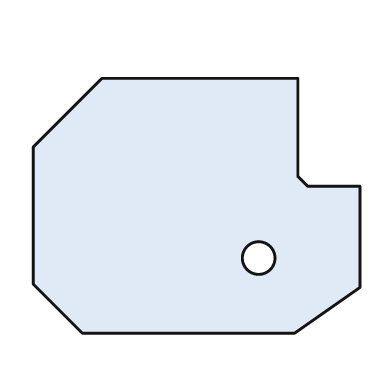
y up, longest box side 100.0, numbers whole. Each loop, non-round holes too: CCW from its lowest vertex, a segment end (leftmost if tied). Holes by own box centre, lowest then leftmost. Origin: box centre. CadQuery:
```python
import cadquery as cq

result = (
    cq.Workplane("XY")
    .moveTo(-35.0, -39.0)
    .lineTo(30.0, -39.0)
    .lineTo(50.0, -25.0)
    .lineTo(50.0, 6.0)
    .lineTo(34.0, 6.0)
    .lineTo(31.0, 9.0)
    .lineTo(31.0, 39.0)
    .lineTo(-29.0, 39.0)
    .lineTo(-50.0, 18.0)
    .lineTo(-50.0, -24.0)
    .close()
    .moveTo(19.0, -16.0)
    .circle(5.0)
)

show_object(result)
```